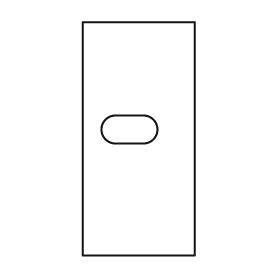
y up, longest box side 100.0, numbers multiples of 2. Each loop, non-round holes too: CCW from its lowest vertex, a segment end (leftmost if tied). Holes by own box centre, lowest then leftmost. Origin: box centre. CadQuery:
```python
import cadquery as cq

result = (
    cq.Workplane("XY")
    .moveTo(-24.0, -50.0)
    .lineTo(24.0, -50.0)
    .lineTo(24.0, 50.0)
    .lineTo(-24.0, 50.0)
    .close()
    .moveTo(-10.0, -2.0)
    .lineTo(2.0, -2.0)
    .threePointArc((8.0, 4.0), (2.0, 10.0))
    .lineTo(-10.0, 10.0)
    .threePointArc((-16.0, 4.0), (-10.0, -2.0))
    .close()
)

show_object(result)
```